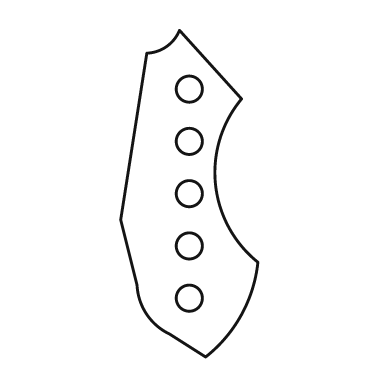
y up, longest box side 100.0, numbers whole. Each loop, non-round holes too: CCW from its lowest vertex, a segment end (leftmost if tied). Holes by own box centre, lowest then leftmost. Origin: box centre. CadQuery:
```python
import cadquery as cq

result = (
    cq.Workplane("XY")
    .moveTo(5.0, -50.0)
    .threePointArc((16.0, -37.0), (21.0, -21.0))
    .threePointArc((8.0, 3.0), (16.0, 29.0))
    .lineTo(-3.0, 50.0)
    .threePointArc((-7.0, 45.0), (-13.0, 43.0))
    .lineTo(-21.0, -8.0)
    .lineTo(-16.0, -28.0)
    .threePointArc((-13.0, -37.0), (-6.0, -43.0))
    .close()
    .moveTo(0.0, -32.0)
    .circle(4.0)
    .moveTo(0.0, -16.0)
    .circle(4.0)
    .moveTo(0.0, 0.0)
    .circle(4.0)
    .moveTo(0.0, 16.0)
    .circle(4.0)
    .moveTo(0.0, 32.0)
    .circle(4.0)
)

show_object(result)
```